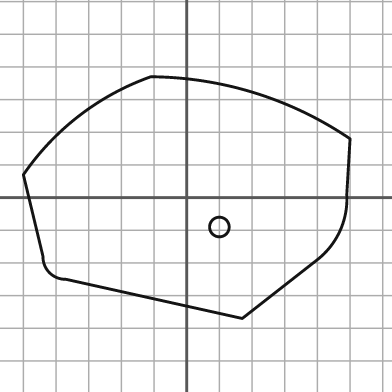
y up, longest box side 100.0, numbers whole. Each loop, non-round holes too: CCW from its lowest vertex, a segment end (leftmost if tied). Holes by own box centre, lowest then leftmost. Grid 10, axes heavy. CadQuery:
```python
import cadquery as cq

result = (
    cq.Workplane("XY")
    .moveTo(17.0, -37.0)
    .lineTo(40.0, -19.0)
    .threePointArc((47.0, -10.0), (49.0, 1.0))
    .lineTo(50.0, 18.0)
    .threePointArc((21.0, 32.0), (-11.0, 37.0))
    .threePointArc((-33.0, 25.0), (-50.0, 7.0))
    .lineTo(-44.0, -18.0)
    .threePointArc((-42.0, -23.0), (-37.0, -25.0))
    .close()
    .moveTo(10.0, -9.0)
    .circle(3.0)
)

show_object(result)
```